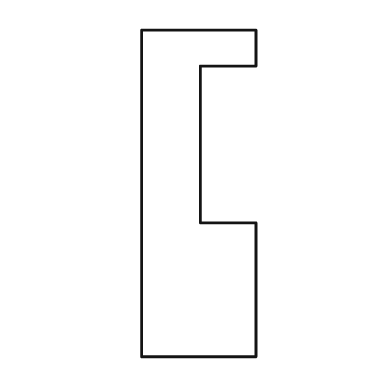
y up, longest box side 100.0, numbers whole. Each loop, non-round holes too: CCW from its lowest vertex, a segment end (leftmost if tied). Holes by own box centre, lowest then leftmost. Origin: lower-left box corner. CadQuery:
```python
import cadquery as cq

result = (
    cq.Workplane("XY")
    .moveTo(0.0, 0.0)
    .lineTo(35.0, 0.0)
    .lineTo(35.0, 41.0)
    .lineTo(18.0, 41.0)
    .lineTo(18.0, 89.0)
    .lineTo(35.0, 89.0)
    .lineTo(35.0, 100.0)
    .lineTo(0.0, 100.0)
    .close()
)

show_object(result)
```